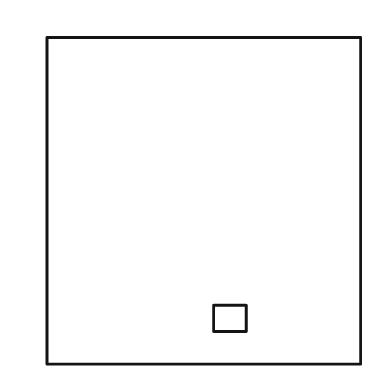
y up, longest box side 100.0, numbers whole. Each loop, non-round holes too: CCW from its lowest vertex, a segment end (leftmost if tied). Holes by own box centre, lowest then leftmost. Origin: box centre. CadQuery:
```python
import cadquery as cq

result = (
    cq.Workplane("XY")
    .moveTo(-48.0, -50.0)
    .lineTo(48.0, -50.0)
    .lineTo(48.0, 50.0)
    .lineTo(-48.0, 50.0)
    .close()
    .moveTo(3.0, -40.0)
    .lineTo(13.0, -40.0)
    .lineTo(13.0, -32.0)
    .lineTo(3.0, -32.0)
    .close()
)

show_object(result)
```